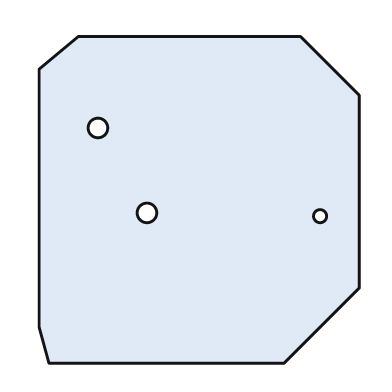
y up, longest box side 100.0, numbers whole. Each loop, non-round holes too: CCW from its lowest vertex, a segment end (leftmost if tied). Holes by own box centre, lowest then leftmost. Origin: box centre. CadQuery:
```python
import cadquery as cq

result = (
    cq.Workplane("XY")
    .moveTo(-46.0, -50.0)
    .lineTo(26.0, -50.0)
    .lineTo(49.0, -27.0)
    .lineTo(49.0, 32.0)
    .lineTo(31.0, 50.0)
    .lineTo(-37.0, 50.0)
    .lineTo(-49.0, 40.0)
    .lineTo(-49.0, -39.0)
    .close()
    .moveTo(37.0, -5.0)
    .circle(2.0)
    .moveTo(-16.0, -4.0)
    .circle(3.0)
    .moveTo(-31.0, 22.0)
    .circle(3.0)
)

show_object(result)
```